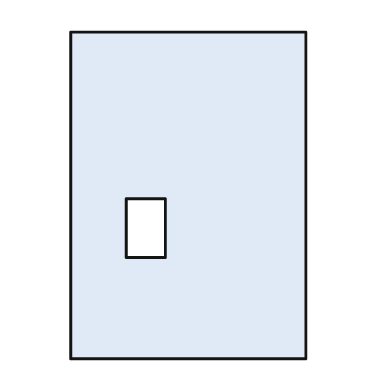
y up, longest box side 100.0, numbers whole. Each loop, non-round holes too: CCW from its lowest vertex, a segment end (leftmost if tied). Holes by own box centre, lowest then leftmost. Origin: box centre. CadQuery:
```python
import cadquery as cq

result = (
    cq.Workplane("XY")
    .moveTo(-36.0, -50.0)
    .lineTo(36.0, -50.0)
    .lineTo(36.0, 50.0)
    .lineTo(-36.0, 50.0)
    .close()
    .moveTo(-19.0, -19.0)
    .lineTo(-7.0, -19.0)
    .lineTo(-7.0, -1.0)
    .lineTo(-19.0, -1.0)
    .close()
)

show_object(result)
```